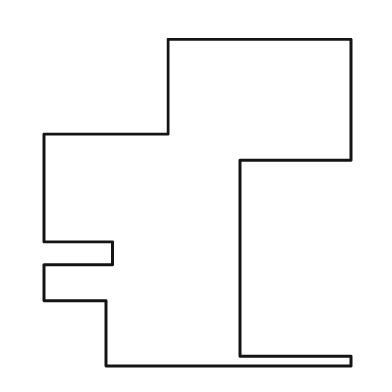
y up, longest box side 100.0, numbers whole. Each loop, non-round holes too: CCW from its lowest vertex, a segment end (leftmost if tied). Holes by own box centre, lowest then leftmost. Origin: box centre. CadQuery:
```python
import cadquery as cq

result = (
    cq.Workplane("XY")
    .moveTo(-28.0, -50.0)
    .lineTo(47.0, -50.0)
    .lineTo(47.0, -47.0)
    .lineTo(13.0, -47.0)
    .lineTo(13.0, 13.0)
    .lineTo(47.0, 13.0)
    .lineTo(47.0, 50.0)
    .lineTo(-9.0, 50.0)
    .lineTo(-9.0, 21.0)
    .lineTo(-47.0, 21.0)
    .lineTo(-47.0, -12.0)
    .lineTo(-26.0, -12.0)
    .lineTo(-26.0, -19.0)
    .lineTo(-47.0, -19.0)
    .lineTo(-47.0, -30.0)
    .lineTo(-28.0, -30.0)
    .close()
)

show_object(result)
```